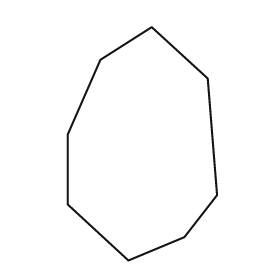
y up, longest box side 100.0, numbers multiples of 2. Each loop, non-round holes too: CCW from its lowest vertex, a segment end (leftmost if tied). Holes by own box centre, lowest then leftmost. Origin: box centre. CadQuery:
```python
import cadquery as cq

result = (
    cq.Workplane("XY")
    .moveTo(-6.0, -50.0)
    .lineTo(18.0, -40.0)
    .lineTo(32.0, -22.0)
    .lineTo(28.0, 28.0)
    .lineTo(4.0, 50.0)
    .lineTo(-18.0, 36.0)
    .lineTo(-32.0, 4.0)
    .lineTo(-32.0, -26.0)
    .close()
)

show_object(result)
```